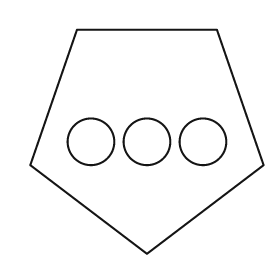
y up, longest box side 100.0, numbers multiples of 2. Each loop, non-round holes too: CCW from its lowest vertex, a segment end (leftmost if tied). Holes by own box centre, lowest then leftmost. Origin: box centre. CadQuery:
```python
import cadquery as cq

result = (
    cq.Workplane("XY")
    .moveTo(0.0, -48.0)
    .lineTo(50.0, -10.0)
    .lineTo(30.0, 48.0)
    .lineTo(-30.0, 48.0)
    .lineTo(-50.0, -10.0)
    .close()
    .moveTo(-24.0, 0.0)
    .circle(10.0)
    .moveTo(0.0, 0.0)
    .circle(10.0)
    .moveTo(24.0, 0.0)
    .circle(10.0)
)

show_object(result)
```